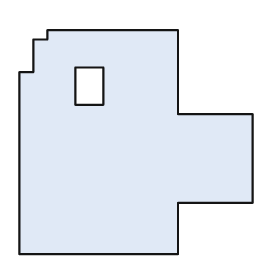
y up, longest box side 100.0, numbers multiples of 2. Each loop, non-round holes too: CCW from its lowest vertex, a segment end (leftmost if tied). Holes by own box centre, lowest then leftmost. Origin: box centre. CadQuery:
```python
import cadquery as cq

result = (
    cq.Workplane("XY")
    .moveTo(-50.0, -48.0)
    .lineTo(18.0, -48.0)
    .lineTo(18.0, -26.0)
    .lineTo(50.0, -26.0)
    .lineTo(50.0, 12.0)
    .lineTo(18.0, 12.0)
    .lineTo(18.0, 48.0)
    .lineTo(-38.0, 48.0)
    .lineTo(-38.0, 44.0)
    .lineTo(-44.0, 44.0)
    .lineTo(-44.0, 30.0)
    .lineTo(-50.0, 30.0)
    .close()
    .moveTo(-26.0, 16.0)
    .lineTo(-14.0, 16.0)
    .lineTo(-14.0, 32.0)
    .lineTo(-26.0, 32.0)
    .close()
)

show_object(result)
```